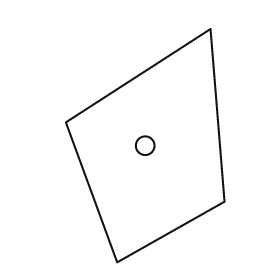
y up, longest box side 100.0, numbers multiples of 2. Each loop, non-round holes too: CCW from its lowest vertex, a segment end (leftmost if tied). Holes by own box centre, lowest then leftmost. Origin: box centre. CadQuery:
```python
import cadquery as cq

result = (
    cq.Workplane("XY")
    .moveTo(-12.0, -50.0)
    .lineTo(34.0, -24.0)
    .lineTo(28.0, 50.0)
    .lineTo(-34.0, 10.0)
    .close()
    .moveTo(0.0, 0.0)
    .circle(4.0)
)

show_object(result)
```